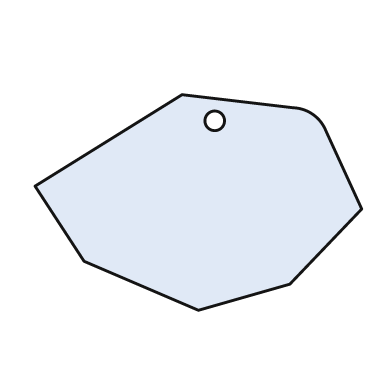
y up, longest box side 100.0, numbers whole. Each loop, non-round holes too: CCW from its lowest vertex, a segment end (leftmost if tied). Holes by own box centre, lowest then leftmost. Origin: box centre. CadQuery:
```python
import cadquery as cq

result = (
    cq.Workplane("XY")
    .moveTo(0.0, -33.0)
    .lineTo(28.0, -25.0)
    .lineTo(50.0, -2.0)
    .lineTo(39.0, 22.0)
    .threePointArc((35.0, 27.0), (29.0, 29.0))
    .lineTo(-5.0, 33.0)
    .lineTo(-50.0, 5.0)
    .lineTo(-35.0, -18.0)
    .close()
    .moveTo(5.0, 25.0)
    .circle(3.0)
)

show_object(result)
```